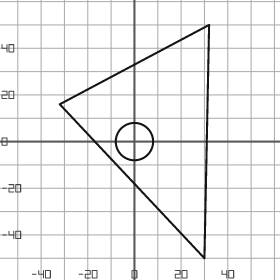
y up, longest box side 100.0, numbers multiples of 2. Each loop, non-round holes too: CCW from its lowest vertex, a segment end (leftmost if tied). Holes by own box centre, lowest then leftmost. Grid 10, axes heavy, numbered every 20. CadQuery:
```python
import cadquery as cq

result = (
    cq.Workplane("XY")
    .moveTo(30.0, -50.0)
    .lineTo(32.0, 50.0)
    .lineTo(-32.0, 16.0)
    .close()
    .moveTo(0.0, 0.0)
    .circle(8.0)
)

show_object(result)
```